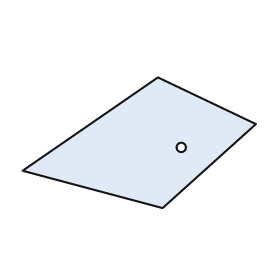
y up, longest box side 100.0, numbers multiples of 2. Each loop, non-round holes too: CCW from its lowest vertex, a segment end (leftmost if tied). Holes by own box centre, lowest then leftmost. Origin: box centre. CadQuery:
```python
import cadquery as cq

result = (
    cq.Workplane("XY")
    .moveTo(10.0, -28.0)
    .lineTo(50.0, 8.0)
    .lineTo(8.0, 28.0)
    .lineTo(-50.0, -12.0)
    .close()
    .moveTo(18.0, -2.0)
    .circle(2.0)
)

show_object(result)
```